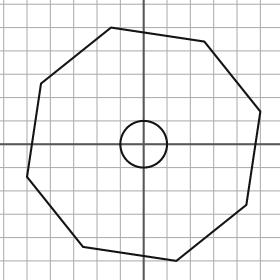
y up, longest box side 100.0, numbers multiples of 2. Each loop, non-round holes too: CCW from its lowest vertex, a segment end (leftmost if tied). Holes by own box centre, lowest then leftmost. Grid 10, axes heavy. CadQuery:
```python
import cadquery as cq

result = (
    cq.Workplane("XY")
    .moveTo(14.0, -50.0)
    .lineTo(44.0, -26.0)
    .lineTo(50.0, 14.0)
    .lineTo(26.0, 44.0)
    .lineTo(-14.0, 50.0)
    .lineTo(-44.0, 26.0)
    .lineTo(-50.0, -14.0)
    .lineTo(-26.0, -44.0)
    .close()
    .moveTo(0.0, 0.0)
    .circle(10.0)
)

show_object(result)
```